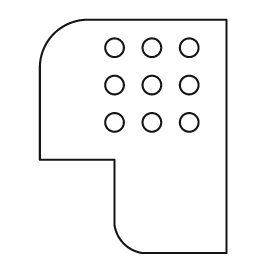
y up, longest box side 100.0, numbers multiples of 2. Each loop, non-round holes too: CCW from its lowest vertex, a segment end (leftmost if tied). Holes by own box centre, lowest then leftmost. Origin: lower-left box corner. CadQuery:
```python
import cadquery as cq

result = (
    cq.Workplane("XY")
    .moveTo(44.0, 0.0)
    .lineTo(80.0, 0.0)
    .lineTo(80.0, 100.0)
    .lineTo(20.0, 100.0)
    .threePointArc((6.0, 94.0), (0.0, 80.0))
    .lineTo(0.0, 40.0)
    .lineTo(32.0, 40.0)
    .lineTo(32.0, 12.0)
    .threePointArc((36.0, 4.0), (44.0, 0.0))
    .close()
    .moveTo(32.0, 56.0)
    .circle(4.0)
    .moveTo(48.0, 56.0)
    .circle(4.0)
    .moveTo(64.0, 56.0)
    .circle(4.0)
    .moveTo(32.0, 72.0)
    .circle(4.0)
    .moveTo(48.0, 72.0)
    .circle(4.0)
    .moveTo(64.0, 72.0)
    .circle(4.0)
    .moveTo(32.0, 88.0)
    .circle(4.0)
    .moveTo(48.0, 88.0)
    .circle(4.0)
    .moveTo(64.0, 88.0)
    .circle(4.0)
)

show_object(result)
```